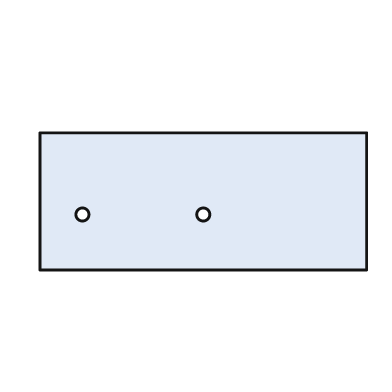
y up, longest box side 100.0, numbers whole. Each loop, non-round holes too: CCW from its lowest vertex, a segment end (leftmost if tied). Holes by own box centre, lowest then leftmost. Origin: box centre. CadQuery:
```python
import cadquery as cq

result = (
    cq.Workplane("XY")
    .moveTo(-50.0, -21.0)
    .lineTo(50.0, -21.0)
    .lineTo(50.0, 21.0)
    .lineTo(-50.0, 21.0)
    .close()
    .moveTo(-37.0, -4.0)
    .circle(2.0)
    .moveTo(0.0, -4.0)
    .circle(2.0)
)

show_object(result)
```